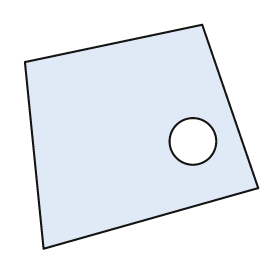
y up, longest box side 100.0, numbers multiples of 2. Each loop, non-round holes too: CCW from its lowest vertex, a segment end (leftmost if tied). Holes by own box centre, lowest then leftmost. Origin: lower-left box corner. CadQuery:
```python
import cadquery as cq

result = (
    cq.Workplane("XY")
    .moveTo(8.0, 0.0)
    .lineTo(100.0, 26.0)
    .lineTo(76.0, 96.0)
    .lineTo(0.0, 80.0)
    .close()
    .moveTo(72.0, 46.0)
    .circle(10.0)
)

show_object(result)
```